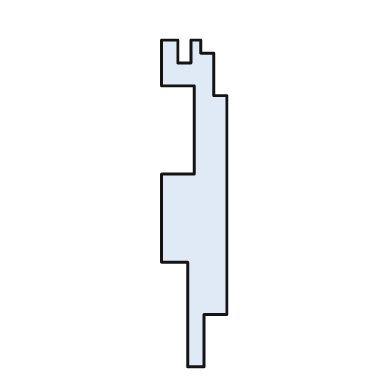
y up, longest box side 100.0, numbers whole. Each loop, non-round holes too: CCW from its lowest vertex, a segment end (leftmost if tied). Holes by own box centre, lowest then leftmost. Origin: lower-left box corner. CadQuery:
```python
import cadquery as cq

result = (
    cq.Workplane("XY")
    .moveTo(8.0, 0.0)
    .lineTo(13.0, 0.0)
    .lineTo(13.0, 16.0)
    .lineTo(20.0, 16.0)
    .lineTo(20.0, 83.0)
    .lineTo(16.0, 83.0)
    .lineTo(16.0, 96.0)
    .lineTo(12.0, 96.0)
    .lineTo(12.0, 100.0)
    .lineTo(9.0, 100.0)
    .lineTo(9.0, 93.0)
    .lineTo(5.0, 93.0)
    .lineTo(5.0, 100.0)
    .lineTo(0.0, 100.0)
    .lineTo(0.0, 86.0)
    .lineTo(10.0, 86.0)
    .lineTo(10.0, 59.0)
    .lineTo(0.0, 59.0)
    .lineTo(0.0, 32.0)
    .lineTo(8.0, 32.0)
    .close()
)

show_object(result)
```